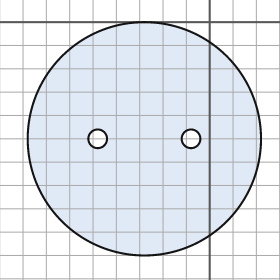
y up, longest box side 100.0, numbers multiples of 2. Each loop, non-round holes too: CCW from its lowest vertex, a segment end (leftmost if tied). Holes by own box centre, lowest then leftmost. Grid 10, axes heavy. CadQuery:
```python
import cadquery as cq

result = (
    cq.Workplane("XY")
    .moveTo(-28.0, -50.0)
    .circle(50.0)
    .moveTo(-48.0, -50.0)
    .circle(4.0)
    .moveTo(-8.0, -50.0)
    .circle(4.0)
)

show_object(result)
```